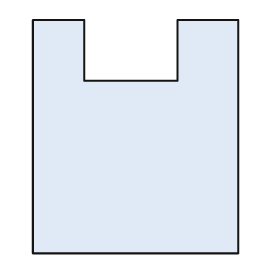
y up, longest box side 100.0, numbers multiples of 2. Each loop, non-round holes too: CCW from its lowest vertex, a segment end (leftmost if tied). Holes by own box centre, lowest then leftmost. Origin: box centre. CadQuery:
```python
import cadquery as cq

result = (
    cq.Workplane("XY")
    .moveTo(-44.0, -50.0)
    .lineTo(44.0, -50.0)
    .lineTo(44.0, 50.0)
    .lineTo(18.0, 50.0)
    .lineTo(18.0, 24.0)
    .lineTo(-22.0, 24.0)
    .lineTo(-22.0, 50.0)
    .lineTo(-44.0, 50.0)
    .close()
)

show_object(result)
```